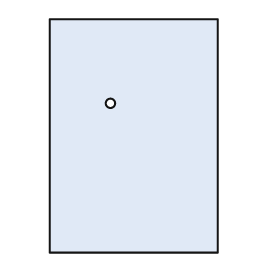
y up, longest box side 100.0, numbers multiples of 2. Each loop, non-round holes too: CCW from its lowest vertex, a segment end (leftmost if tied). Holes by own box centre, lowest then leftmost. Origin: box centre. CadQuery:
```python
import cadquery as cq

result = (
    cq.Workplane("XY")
    .moveTo(-36.0, -50.0)
    .lineTo(36.0, -50.0)
    .lineTo(36.0, 50.0)
    .lineTo(-36.0, 50.0)
    .close()
    .moveTo(-10.0, 14.0)
    .circle(2.0)
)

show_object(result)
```